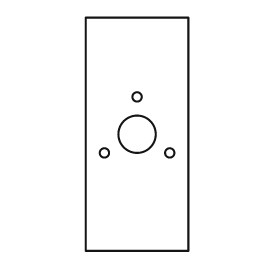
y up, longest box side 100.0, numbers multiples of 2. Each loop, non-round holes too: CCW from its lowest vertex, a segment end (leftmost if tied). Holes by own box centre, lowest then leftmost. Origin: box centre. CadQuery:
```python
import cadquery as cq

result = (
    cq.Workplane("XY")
    .moveTo(-22.0, -50.0)
    .lineTo(22.0, -50.0)
    .lineTo(22.0, 50.0)
    .lineTo(-22.0, 50.0)
    .close()
    .moveTo(-14.0, -8.0)
    .circle(2.0)
    .moveTo(14.0, -8.0)
    .circle(2.0)
    .moveTo(0.0, 0.0)
    .circle(8.0)
    .moveTo(0.0, 16.0)
    .circle(2.0)
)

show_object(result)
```